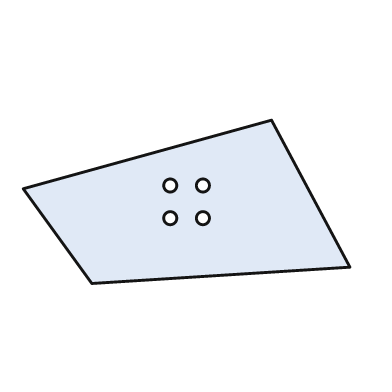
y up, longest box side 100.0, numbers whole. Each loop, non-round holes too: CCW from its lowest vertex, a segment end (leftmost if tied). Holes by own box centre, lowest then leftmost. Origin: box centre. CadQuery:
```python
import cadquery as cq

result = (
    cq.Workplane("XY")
    .moveTo(-29.0, -25.0)
    .lineTo(50.0, -20.0)
    .lineTo(26.0, 25.0)
    .lineTo(-50.0, 4.0)
    .close()
    .moveTo(-5.0, -5.0)
    .circle(2.0)
    .moveTo(5.0, -5.0)
    .circle(2.0)
    .moveTo(-5.0, 5.0)
    .circle(2.0)
    .moveTo(5.0, 5.0)
    .circle(2.0)
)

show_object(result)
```